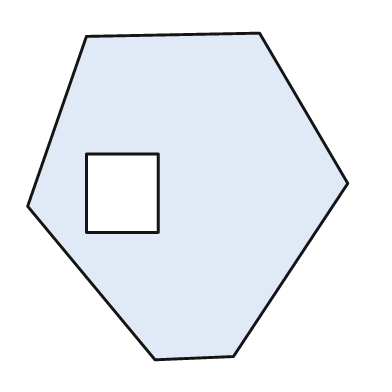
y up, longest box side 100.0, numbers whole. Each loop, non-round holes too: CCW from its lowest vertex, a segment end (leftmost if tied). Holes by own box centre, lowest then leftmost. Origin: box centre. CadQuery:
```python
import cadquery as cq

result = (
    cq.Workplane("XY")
    .moveTo(-10.0, -50.0)
    .lineTo(14.0, -49.0)
    .lineTo(49.0, 4.0)
    .lineTo(22.0, 50.0)
    .lineTo(-31.0, 49.0)
    .lineTo(-49.0, -3.0)
    .close()
    .moveTo(-31.0, -11.0)
    .lineTo(-9.0, -11.0)
    .lineTo(-9.0, 13.0)
    .lineTo(-31.0, 13.0)
    .close()
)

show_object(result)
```